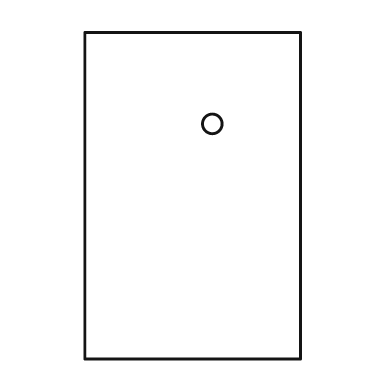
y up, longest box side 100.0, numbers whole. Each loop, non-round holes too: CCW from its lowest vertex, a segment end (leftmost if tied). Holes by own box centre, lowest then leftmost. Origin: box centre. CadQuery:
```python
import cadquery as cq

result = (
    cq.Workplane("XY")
    .moveTo(-33.0, -50.0)
    .lineTo(33.0, -50.0)
    .lineTo(33.0, 50.0)
    .lineTo(-33.0, 50.0)
    .close()
    .moveTo(6.0, 22.0)
    .circle(3.0)
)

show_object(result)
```